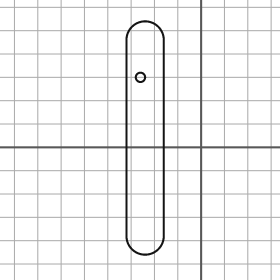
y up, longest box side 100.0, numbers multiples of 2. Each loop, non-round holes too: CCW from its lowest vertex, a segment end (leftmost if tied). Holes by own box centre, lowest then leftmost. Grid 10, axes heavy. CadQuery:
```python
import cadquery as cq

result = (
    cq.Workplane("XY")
    .moveTo(-32.0, -38.0)
    .threePointArc((-24.0, -46.0), (-16.0, -38.0))
    .lineTo(-16.0, 46.0)
    .threePointArc((-24.0, 54.0), (-32.0, 46.0))
    .close()
    .moveTo(-26.0, 30.0)
    .circle(2.0)
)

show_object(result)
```